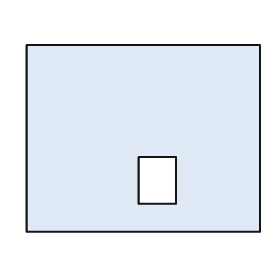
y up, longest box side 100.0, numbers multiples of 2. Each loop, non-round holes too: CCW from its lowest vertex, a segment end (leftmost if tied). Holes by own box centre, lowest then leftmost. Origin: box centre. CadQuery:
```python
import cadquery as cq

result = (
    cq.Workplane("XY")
    .moveTo(-50.0, -40.0)
    .lineTo(50.0, -40.0)
    .lineTo(50.0, 40.0)
    .lineTo(-50.0, 40.0)
    .close()
    .moveTo(-2.0, -28.0)
    .lineTo(14.0, -28.0)
    .lineTo(14.0, -8.0)
    .lineTo(-2.0, -8.0)
    .close()
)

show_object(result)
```